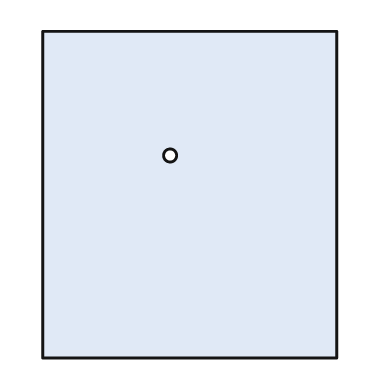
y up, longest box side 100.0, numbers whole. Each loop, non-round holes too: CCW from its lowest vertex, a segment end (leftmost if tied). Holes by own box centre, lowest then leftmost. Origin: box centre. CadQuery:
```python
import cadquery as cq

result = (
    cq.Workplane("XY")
    .moveTo(-45.0, -50.0)
    .lineTo(45.0, -50.0)
    .lineTo(45.0, 50.0)
    .lineTo(-45.0, 50.0)
    .close()
    .moveTo(-6.0, 12.0)
    .circle(2.0)
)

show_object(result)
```